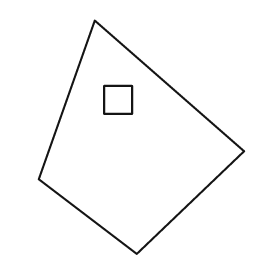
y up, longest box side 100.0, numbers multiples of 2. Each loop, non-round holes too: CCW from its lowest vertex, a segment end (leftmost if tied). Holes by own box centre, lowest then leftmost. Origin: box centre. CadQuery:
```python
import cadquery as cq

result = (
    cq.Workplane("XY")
    .moveTo(-2.0, -50.0)
    .lineTo(44.0, -6.0)
    .lineTo(-20.0, 50.0)
    .lineTo(-44.0, -18.0)
    .close()
    .moveTo(-16.0, 10.0)
    .lineTo(-4.0, 10.0)
    .lineTo(-4.0, 22.0)
    .lineTo(-16.0, 22.0)
    .close()
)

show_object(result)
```